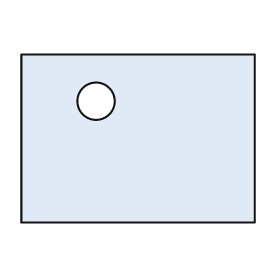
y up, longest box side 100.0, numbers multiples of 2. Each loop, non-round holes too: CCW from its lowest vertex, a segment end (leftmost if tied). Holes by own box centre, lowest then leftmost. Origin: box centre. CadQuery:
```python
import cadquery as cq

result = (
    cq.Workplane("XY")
    .moveTo(-50.0, -36.0)
    .lineTo(50.0, -36.0)
    .lineTo(50.0, 36.0)
    .lineTo(-50.0, 36.0)
    .close()
    .moveTo(-18.0, 16.0)
    .circle(8.0)
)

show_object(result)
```